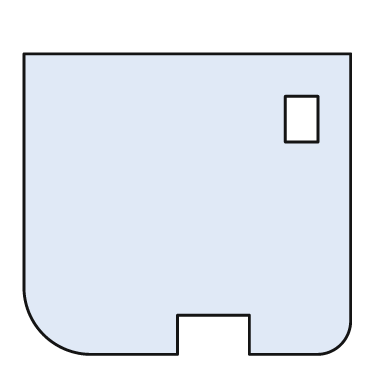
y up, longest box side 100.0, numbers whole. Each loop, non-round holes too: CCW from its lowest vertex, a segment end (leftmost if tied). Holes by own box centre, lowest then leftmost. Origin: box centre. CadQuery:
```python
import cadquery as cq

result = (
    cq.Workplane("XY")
    .moveTo(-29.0, -46.0)
    .lineTo(-3.0, -46.0)
    .lineTo(-3.0, -34.0)
    .lineTo(19.0, -34.0)
    .lineTo(19.0, -46.0)
    .lineTo(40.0, -46.0)
    .threePointArc((47.0, -43.0), (50.0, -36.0))
    .lineTo(50.0, 46.0)
    .lineTo(-50.0, 46.0)
    .lineTo(-50.0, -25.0)
    .threePointArc((-44.0, -40.0), (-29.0, -46.0))
    .close()
    .moveTo(30.0, 19.0)
    .lineTo(40.0, 19.0)
    .lineTo(40.0, 33.0)
    .lineTo(30.0, 33.0)
    .close()
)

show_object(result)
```